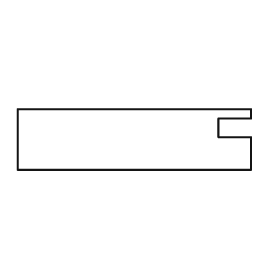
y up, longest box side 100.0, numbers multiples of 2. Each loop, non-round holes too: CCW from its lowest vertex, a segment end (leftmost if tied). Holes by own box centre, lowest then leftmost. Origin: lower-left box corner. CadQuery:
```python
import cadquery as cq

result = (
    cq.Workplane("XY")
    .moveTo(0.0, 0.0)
    .lineTo(100.0, 0.0)
    .lineTo(100.0, 14.0)
    .lineTo(86.0, 14.0)
    .lineTo(86.0, 22.0)
    .lineTo(100.0, 22.0)
    .lineTo(100.0, 26.0)
    .lineTo(0.0, 26.0)
    .close()
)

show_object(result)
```